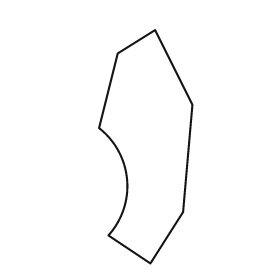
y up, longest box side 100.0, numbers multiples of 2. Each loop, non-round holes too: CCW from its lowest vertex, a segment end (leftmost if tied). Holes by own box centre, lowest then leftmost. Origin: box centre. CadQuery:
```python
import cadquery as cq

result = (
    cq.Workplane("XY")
    .moveTo(2.0, -50.0)
    .lineTo(16.0, -28.0)
    .lineTo(20.0, 18.0)
    .lineTo(4.0, 50.0)
    .lineTo(-12.0, 40.0)
    .lineTo(-20.0, 8.0)
    .threePointArc((-8.0, -14.0), (-16.0, -38.0))
    .close()
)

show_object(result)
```